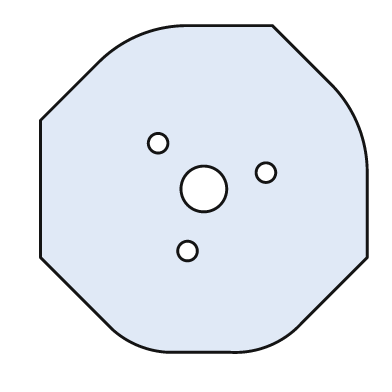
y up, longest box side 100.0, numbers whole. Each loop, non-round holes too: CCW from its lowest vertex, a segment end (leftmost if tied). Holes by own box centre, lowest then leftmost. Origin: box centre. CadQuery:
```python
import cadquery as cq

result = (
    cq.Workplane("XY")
    .moveTo(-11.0, -50.0)
    .lineTo(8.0, -50.0)
    .threePointArc((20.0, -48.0), (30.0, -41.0))
    .lineTo(50.0, -21.0)
    .lineTo(50.0, 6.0)
    .threePointArc((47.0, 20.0), (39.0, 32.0))
    .lineTo(21.0, 50.0)
    .lineTo(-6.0, 50.0)
    .threePointArc((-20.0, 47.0), (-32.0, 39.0))
    .lineTo(-50.0, 21.0)
    .lineTo(-50.0, -21.0)
    .lineTo(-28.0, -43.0)
    .threePointArc((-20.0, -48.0), (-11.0, -50.0))
    .close()
    .moveTo(-5.0, -19.0)
    .circle(3.0)
    .moveTo(0.0, 0.0)
    .circle(7.0)
    .moveTo(19.0, 5.0)
    .circle(3.0)
    .moveTo(-14.0, 14.0)
    .circle(3.0)
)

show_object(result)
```